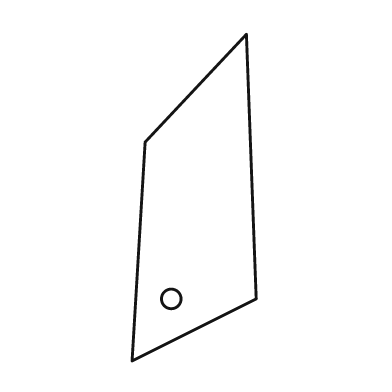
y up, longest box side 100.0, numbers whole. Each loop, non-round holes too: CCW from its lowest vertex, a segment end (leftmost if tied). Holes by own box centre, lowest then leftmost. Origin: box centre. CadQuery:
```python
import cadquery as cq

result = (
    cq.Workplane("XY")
    .moveTo(-19.0, -50.0)
    .lineTo(19.0, -31.0)
    .lineTo(16.0, 50.0)
    .lineTo(-15.0, 17.0)
    .close()
    .moveTo(-7.0, -31.0)
    .circle(3.0)
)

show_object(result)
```